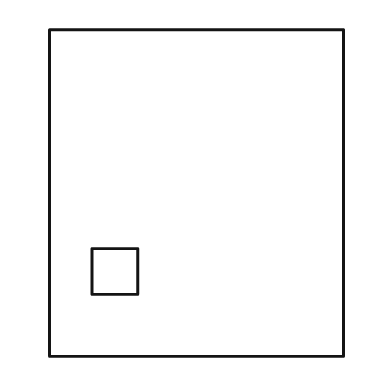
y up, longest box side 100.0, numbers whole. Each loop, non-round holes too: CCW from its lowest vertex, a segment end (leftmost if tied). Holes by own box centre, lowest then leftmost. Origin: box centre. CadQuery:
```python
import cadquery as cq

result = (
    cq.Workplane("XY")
    .moveTo(-45.0, -50.0)
    .lineTo(45.0, -50.0)
    .lineTo(45.0, 50.0)
    .lineTo(-45.0, 50.0)
    .close()
    .moveTo(-32.0, -31.0)
    .lineTo(-18.0, -31.0)
    .lineTo(-18.0, -17.0)
    .lineTo(-32.0, -17.0)
    .close()
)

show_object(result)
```